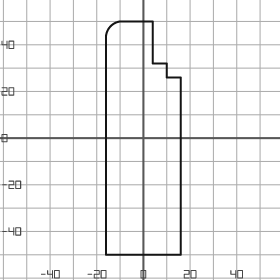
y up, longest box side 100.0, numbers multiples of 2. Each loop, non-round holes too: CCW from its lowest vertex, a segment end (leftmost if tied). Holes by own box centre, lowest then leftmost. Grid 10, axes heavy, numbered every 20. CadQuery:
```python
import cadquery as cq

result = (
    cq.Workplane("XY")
    .moveTo(-16.0, -50.0)
    .lineTo(16.0, -50.0)
    .lineTo(16.0, 26.0)
    .lineTo(10.0, 26.0)
    .lineTo(10.0, 32.0)
    .lineTo(4.0, 32.0)
    .lineTo(4.0, 50.0)
    .lineTo(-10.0, 50.0)
    .threePointArc((-14.0, 48.0), (-16.0, 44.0))
    .close()
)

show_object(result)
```